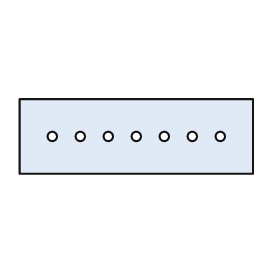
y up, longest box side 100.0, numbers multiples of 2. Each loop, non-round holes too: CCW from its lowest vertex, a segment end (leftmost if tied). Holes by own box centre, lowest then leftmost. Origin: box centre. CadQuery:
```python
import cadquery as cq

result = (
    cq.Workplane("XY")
    .moveTo(-50.0, -16.0)
    .lineTo(50.0, -16.0)
    .lineTo(50.0, 16.0)
    .lineTo(-50.0, 16.0)
    .close()
    .moveTo(-36.0, 0.0)
    .circle(2.0)
    .moveTo(-24.0, 0.0)
    .circle(2.0)
    .moveTo(-12.0, 0.0)
    .circle(2.0)
    .moveTo(0.0, 0.0)
    .circle(2.0)
    .moveTo(12.0, 0.0)
    .circle(2.0)
    .moveTo(24.0, 0.0)
    .circle(2.0)
    .moveTo(36.0, 0.0)
    .circle(2.0)
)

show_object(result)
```